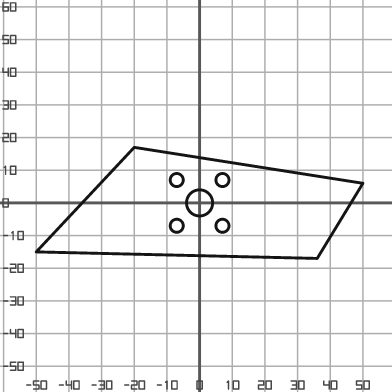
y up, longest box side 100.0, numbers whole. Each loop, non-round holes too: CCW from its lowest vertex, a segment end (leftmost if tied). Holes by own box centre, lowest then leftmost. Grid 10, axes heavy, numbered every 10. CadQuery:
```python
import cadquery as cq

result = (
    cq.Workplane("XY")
    .moveTo(36.0, -17.0)
    .lineTo(50.0, 6.0)
    .lineTo(-20.0, 17.0)
    .lineTo(-50.0, -15.0)
    .close()
    .moveTo(-7.0, -7.0)
    .circle(2.0)
    .moveTo(7.0, -7.0)
    .circle(2.0)
    .moveTo(0.0, 0.0)
    .circle(4.0)
    .moveTo(-7.0, 7.0)
    .circle(2.0)
    .moveTo(7.0, 7.0)
    .circle(2.0)
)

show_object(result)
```